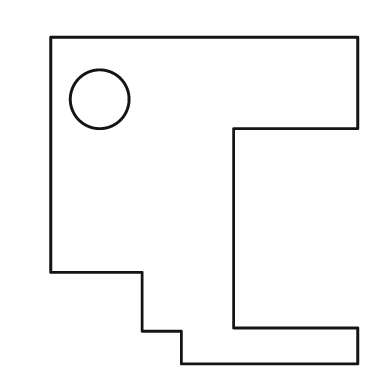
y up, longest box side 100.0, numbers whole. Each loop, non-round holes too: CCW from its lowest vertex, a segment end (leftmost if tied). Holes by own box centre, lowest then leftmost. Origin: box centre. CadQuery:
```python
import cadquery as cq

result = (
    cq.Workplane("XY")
    .moveTo(-7.0, -50.0)
    .lineTo(47.0, -50.0)
    .lineTo(47.0, -39.0)
    .lineTo(9.0, -39.0)
    .lineTo(9.0, 22.0)
    .lineTo(47.0, 22.0)
    .lineTo(47.0, 50.0)
    .lineTo(-47.0, 50.0)
    .lineTo(-47.0, -22.0)
    .lineTo(-19.0, -22.0)
    .lineTo(-19.0, -40.0)
    .lineTo(-7.0, -40.0)
    .close()
    .moveTo(-32.0, 31.0)
    .circle(9.0)
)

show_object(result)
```